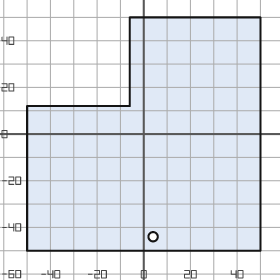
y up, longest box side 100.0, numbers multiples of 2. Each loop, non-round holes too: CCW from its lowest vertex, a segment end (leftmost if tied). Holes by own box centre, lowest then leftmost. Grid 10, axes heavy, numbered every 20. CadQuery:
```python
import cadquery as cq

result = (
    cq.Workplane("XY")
    .moveTo(-50.0, -50.0)
    .lineTo(50.0, -50.0)
    .lineTo(50.0, 50.0)
    .lineTo(-6.0, 50.0)
    .lineTo(-6.0, 12.0)
    .lineTo(-50.0, 12.0)
    .close()
    .moveTo(4.0, -44.0)
    .circle(2.0)
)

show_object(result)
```